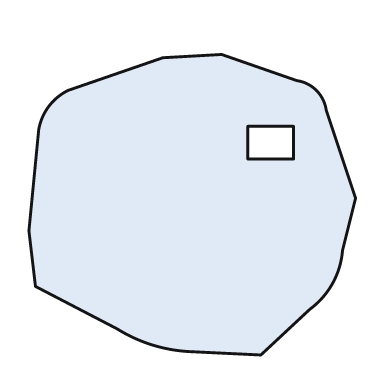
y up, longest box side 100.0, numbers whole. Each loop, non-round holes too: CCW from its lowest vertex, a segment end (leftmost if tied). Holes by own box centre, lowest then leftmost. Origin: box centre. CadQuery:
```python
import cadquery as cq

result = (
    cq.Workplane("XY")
    .moveTo(21.0, -46.0)
    .lineTo(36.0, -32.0)
    .threePointArc((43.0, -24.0), (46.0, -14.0))
    .lineTo(50.0, 2.0)
    .lineTo(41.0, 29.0)
    .threePointArc((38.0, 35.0), (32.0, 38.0))
    .lineTo(9.0, 46.0)
    .lineTo(-9.0, 45.0)
    .lineTo(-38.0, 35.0)
    .threePointArc((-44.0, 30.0), (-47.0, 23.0))
    .lineTo(-50.0, -8.0)
    .lineTo(-48.0, -25.0)
    .lineTo(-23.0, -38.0)
    .threePointArc((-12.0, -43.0), (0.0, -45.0))
    .close()
    .moveTo(17.0, 14.0)
    .lineTo(31.0, 14.0)
    .lineTo(31.0, 24.0)
    .lineTo(17.0, 24.0)
    .close()
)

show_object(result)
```